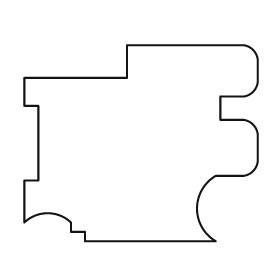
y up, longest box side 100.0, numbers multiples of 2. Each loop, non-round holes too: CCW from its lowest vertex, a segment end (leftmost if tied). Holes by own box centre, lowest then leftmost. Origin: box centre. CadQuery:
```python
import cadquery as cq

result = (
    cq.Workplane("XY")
    .moveTo(-24.0, -42.0)
    .lineTo(32.0, -42.0)
    .threePointArc((24.0, -28.0), (32.0, -14.0))
    .lineTo(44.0, -14.0)
    .threePointArc((48.0, -12.0), (50.0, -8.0))
    .lineTo(50.0, 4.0)
    .threePointArc((48.0, 8.0), (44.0, 10.0))
    .lineTo(34.0, 10.0)
    .lineTo(34.0, 20.0)
    .lineTo(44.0, 20.0)
    .threePointArc((48.0, 22.0), (50.0, 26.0))
    .lineTo(50.0, 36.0)
    .threePointArc((48.0, 40.0), (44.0, 42.0))
    .lineTo(-6.0, 42.0)
    .lineTo(-6.0, 28.0)
    .lineTo(-50.0, 28.0)
    .lineTo(-50.0, 16.0)
    .lineTo(-44.0, 16.0)
    .lineTo(-44.0, -16.0)
    .lineTo(-50.0, -16.0)
    .lineTo(-50.0, -34.0)
    .threePointArc((-40.0, -30.0), (-30.0, -34.0))
    .lineTo(-30.0, -38.0)
    .lineTo(-24.0, -38.0)
    .close()
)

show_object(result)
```